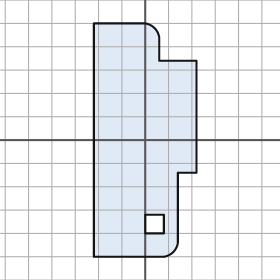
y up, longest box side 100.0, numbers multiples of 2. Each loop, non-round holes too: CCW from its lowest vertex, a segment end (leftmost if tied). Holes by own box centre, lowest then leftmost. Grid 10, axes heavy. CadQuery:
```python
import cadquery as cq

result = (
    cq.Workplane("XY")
    .moveTo(-22.0, -50.0)
    .lineTo(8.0, -50.0)
    .threePointArc((12.0, -48.0), (14.0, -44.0))
    .lineTo(14.0, -14.0)
    .lineTo(22.0, -14.0)
    .lineTo(22.0, 34.0)
    .lineTo(6.0, 34.0)
    .lineTo(6.0, 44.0)
    .threePointArc((4.0, 48.0), (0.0, 50.0))
    .lineTo(-22.0, 50.0)
    .close()
    .moveTo(0.0, -40.0)
    .lineTo(8.0, -40.0)
    .lineTo(8.0, -32.0)
    .lineTo(0.0, -32.0)
    .close()
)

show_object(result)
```